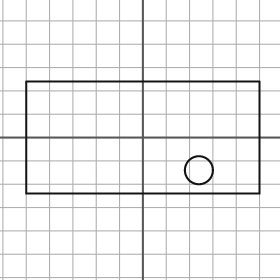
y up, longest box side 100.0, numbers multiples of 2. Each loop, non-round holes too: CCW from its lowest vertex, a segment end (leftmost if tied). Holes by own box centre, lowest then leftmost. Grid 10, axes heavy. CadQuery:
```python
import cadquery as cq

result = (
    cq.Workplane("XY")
    .moveTo(-50.0, -24.0)
    .lineTo(50.0, -24.0)
    .lineTo(50.0, 24.0)
    .lineTo(-50.0, 24.0)
    .close()
    .moveTo(24.0, -14.0)
    .circle(6.0)
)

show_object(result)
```